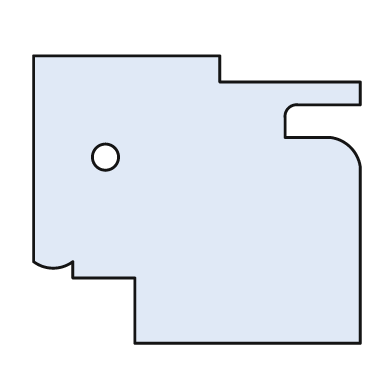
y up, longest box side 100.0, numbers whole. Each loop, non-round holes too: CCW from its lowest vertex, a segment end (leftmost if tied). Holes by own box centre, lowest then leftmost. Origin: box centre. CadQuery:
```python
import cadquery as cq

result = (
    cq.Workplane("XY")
    .moveTo(-19.0, -44.0)
    .lineTo(50.0, -44.0)
    .lineTo(50.0, 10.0)
    .threePointArc((47.0, 16.0), (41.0, 19.0))
    .lineTo(27.0, 19.0)
    .lineTo(27.0, 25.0)
    .threePointArc((28.0, 28.0), (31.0, 29.0))
    .lineTo(50.0, 29.0)
    .lineTo(50.0, 36.0)
    .lineTo(7.0, 36.0)
    .lineTo(7.0, 44.0)
    .lineTo(-50.0, 44.0)
    .lineTo(-50.0, -19.0)
    .threePointArc((-44.0, -21.0), (-38.0, -19.0))
    .lineTo(-38.0, -24.0)
    .lineTo(-19.0, -24.0)
    .close()
    .moveTo(-28.0, 13.0)
    .circle(4.0)
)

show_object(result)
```